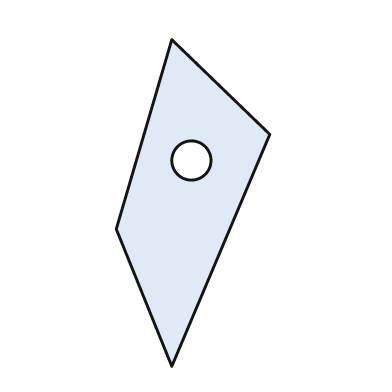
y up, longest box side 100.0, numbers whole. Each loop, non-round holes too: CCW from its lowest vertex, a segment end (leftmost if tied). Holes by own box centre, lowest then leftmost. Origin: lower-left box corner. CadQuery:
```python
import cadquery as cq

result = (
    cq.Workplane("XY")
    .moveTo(17.0, 0.0)
    .lineTo(47.0, 71.0)
    .lineTo(17.0, 100.0)
    .lineTo(0.0, 42.0)
    .close()
    .moveTo(23.0, 63.0)
    .circle(6.0)
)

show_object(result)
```